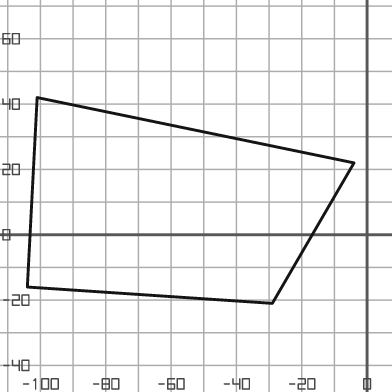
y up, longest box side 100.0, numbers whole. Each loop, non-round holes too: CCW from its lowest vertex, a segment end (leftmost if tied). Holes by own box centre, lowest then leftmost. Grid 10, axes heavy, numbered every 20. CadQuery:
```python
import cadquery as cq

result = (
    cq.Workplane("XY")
    .moveTo(-29.0, -21.0)
    .lineTo(-4.0, 22.0)
    .lineTo(-101.0, 42.0)
    .lineTo(-104.0, -16.0)
    .close()
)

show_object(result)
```